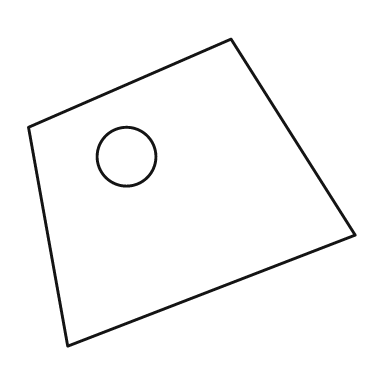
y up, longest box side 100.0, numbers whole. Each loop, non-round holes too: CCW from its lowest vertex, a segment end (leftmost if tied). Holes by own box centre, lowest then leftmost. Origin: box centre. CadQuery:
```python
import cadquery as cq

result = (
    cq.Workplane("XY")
    .moveTo(-38.0, -47.0)
    .lineTo(50.0, -13.0)
    .lineTo(12.0, 47.0)
    .lineTo(-50.0, 20.0)
    .close()
    .moveTo(-20.0, 11.0)
    .circle(9.0)
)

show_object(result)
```